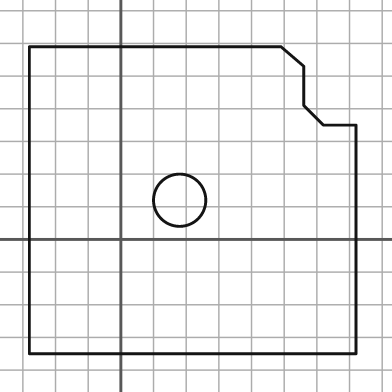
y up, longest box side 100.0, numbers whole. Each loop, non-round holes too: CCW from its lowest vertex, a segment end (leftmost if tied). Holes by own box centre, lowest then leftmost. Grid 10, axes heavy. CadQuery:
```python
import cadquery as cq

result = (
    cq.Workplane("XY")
    .moveTo(-28.0, -35.0)
    .lineTo(72.0, -35.0)
    .lineTo(72.0, 35.0)
    .lineTo(62.0, 35.0)
    .lineTo(56.0, 41.0)
    .lineTo(56.0, 53.0)
    .lineTo(49.0, 59.0)
    .lineTo(-28.0, 59.0)
    .close()
    .moveTo(18.0, 12.0)
    .circle(8.0)
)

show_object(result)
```